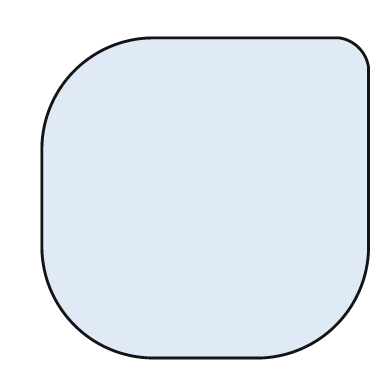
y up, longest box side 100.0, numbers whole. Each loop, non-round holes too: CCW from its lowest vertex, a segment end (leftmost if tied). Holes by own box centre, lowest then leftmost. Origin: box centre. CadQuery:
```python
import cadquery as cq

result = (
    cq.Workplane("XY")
    .moveTo(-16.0, -49.0)
    .lineTo(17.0, -49.0)
    .threePointArc((40.0, -39.0), (50.0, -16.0))
    .lineTo(50.0, 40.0)
    .threePointArc((47.0, 46.0), (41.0, 49.0))
    .lineTo(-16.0, 49.0)
    .threePointArc((-40.0, 39.0), (-50.0, 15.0))
    .lineTo(-50.0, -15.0)
    .threePointArc((-40.0, -39.0), (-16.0, -49.0))
    .close()
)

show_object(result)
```